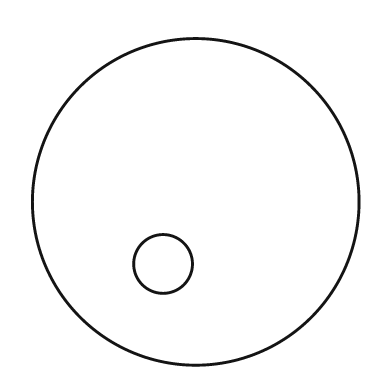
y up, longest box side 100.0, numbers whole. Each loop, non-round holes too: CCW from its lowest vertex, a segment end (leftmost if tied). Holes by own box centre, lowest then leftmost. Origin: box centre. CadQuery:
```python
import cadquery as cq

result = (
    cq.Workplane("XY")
    .moveTo(0.0, 0.0)
    .circle(50.0)
    .moveTo(-10.0, -19.0)
    .circle(9.0)
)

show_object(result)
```